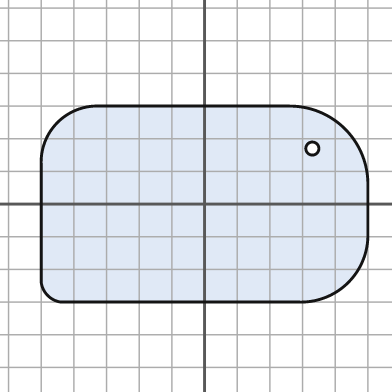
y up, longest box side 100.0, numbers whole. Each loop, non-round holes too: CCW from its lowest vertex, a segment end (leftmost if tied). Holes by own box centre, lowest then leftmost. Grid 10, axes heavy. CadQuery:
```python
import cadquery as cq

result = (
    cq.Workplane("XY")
    .moveTo(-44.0, -30.0)
    .lineTo(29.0, -30.0)
    .threePointArc((44.0, -24.0), (50.0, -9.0))
    .lineTo(50.0, 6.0)
    .threePointArc((43.0, 23.0), (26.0, 30.0))
    .lineTo(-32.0, 30.0)
    .threePointArc((-45.0, 25.0), (-50.0, 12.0))
    .lineTo(-50.0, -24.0)
    .threePointArc((-48.0, -28.0), (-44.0, -30.0))
    .close()
    .moveTo(33.0, 17.0)
    .circle(2.0)
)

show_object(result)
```